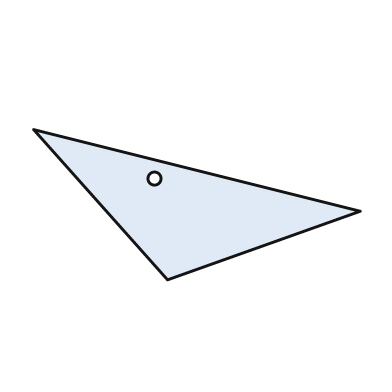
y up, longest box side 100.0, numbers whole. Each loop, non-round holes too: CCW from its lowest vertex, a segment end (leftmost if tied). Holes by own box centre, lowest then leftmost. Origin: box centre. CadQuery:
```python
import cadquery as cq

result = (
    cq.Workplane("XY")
    .moveTo(-9.0, -23.0)
    .lineTo(50.0, -2.0)
    .lineTo(-50.0, 23.0)
    .close()
    .moveTo(-13.0, 8.0)
    .circle(2.0)
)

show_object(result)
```